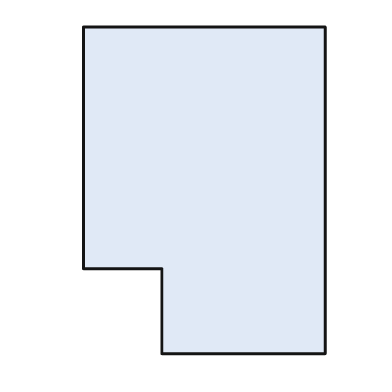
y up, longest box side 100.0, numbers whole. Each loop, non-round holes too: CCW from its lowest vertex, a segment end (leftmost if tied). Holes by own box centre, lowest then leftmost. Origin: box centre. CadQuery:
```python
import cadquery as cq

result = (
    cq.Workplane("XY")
    .moveTo(-13.0, -50.0)
    .lineTo(37.0, -50.0)
    .lineTo(37.0, 50.0)
    .lineTo(-37.0, 50.0)
    .lineTo(-37.0, -24.0)
    .lineTo(-13.0, -24.0)
    .close()
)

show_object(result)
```